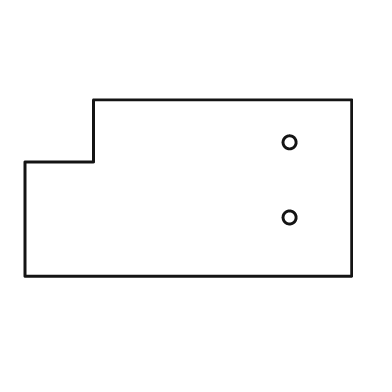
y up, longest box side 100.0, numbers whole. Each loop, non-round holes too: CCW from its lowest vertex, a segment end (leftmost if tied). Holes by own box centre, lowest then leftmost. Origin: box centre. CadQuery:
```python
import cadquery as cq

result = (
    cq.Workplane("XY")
    .moveTo(-50.0, -27.0)
    .lineTo(50.0, -27.0)
    .lineTo(50.0, 27.0)
    .lineTo(-29.0, 27.0)
    .lineTo(-29.0, 8.0)
    .lineTo(-50.0, 8.0)
    .close()
    .moveTo(31.0, -9.0)
    .circle(2.0)
    .moveTo(31.0, 14.0)
    .circle(2.0)
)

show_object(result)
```